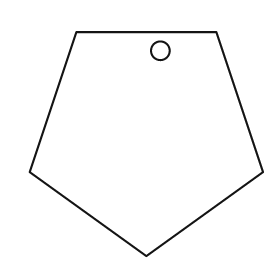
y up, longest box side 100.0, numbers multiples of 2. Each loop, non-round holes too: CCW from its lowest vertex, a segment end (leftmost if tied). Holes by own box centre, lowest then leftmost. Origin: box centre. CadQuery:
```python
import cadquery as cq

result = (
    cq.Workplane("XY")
    .moveTo(0.0, -48.0)
    .lineTo(50.0, -12.0)
    .lineTo(30.0, 48.0)
    .lineTo(-30.0, 48.0)
    .lineTo(-50.0, -12.0)
    .close()
    .moveTo(6.0, 40.0)
    .circle(4.0)
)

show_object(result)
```